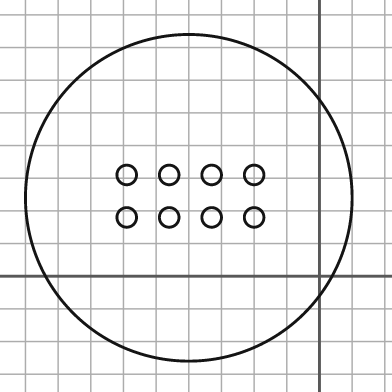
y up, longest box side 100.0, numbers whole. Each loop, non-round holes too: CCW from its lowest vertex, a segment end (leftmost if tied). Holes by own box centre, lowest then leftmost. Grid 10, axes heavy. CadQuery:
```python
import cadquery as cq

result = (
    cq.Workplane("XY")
    .moveTo(-40.0, 24.0)
    .circle(50.0)
    .moveTo(-59.0, 18.0)
    .circle(3.0)
    .moveTo(-46.0, 18.0)
    .circle(3.0)
    .moveTo(-33.0, 18.0)
    .circle(3.0)
    .moveTo(-20.0, 18.0)
    .circle(3.0)
    .moveTo(-59.0, 31.0)
    .circle(3.0)
    .moveTo(-46.0, 31.0)
    .circle(3.0)
    .moveTo(-33.0, 31.0)
    .circle(3.0)
    .moveTo(-20.0, 31.0)
    .circle(3.0)
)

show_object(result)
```